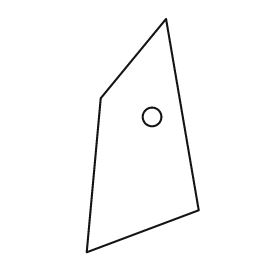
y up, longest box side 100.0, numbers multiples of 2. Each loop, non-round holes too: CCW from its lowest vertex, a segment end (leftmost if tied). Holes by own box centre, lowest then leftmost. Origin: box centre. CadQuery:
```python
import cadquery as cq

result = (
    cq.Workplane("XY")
    .moveTo(-24.0, -50.0)
    .lineTo(24.0, -32.0)
    .lineTo(10.0, 50.0)
    .lineTo(-18.0, 16.0)
    .close()
    .moveTo(4.0, 8.0)
    .circle(4.0)
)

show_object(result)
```